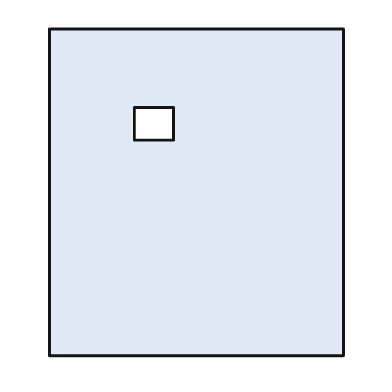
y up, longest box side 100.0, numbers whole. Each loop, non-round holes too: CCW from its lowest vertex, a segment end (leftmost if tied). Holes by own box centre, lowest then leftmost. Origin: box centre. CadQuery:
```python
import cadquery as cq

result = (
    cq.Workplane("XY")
    .moveTo(-45.0, -50.0)
    .lineTo(45.0, -50.0)
    .lineTo(45.0, 50.0)
    .lineTo(-45.0, 50.0)
    .close()
    .moveTo(-19.0, 16.0)
    .lineTo(-7.0, 16.0)
    .lineTo(-7.0, 26.0)
    .lineTo(-19.0, 26.0)
    .close()
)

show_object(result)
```